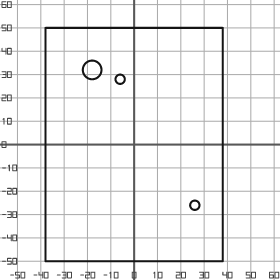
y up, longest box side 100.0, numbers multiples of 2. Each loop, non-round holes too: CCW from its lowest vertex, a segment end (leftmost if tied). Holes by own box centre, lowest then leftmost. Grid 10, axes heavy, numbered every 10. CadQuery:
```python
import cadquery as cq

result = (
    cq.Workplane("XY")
    .moveTo(-38.0, -50.0)
    .lineTo(38.0, -50.0)
    .lineTo(38.0, 50.0)
    .lineTo(-38.0, 50.0)
    .close()
    .moveTo(26.0, -26.0)
    .circle(2.0)
    .moveTo(-6.0, 28.0)
    .circle(2.0)
    .moveTo(-18.0, 32.0)
    .circle(4.0)
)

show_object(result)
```